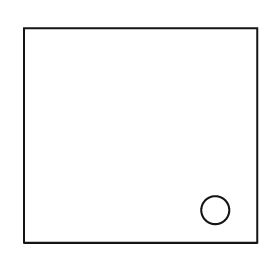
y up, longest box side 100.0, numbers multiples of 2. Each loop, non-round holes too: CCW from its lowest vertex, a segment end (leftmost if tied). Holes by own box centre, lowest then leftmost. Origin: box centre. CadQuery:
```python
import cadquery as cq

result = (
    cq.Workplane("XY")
    .moveTo(-50.0, -46.0)
    .lineTo(50.0, -46.0)
    .lineTo(50.0, 46.0)
    .lineTo(-50.0, 46.0)
    .close()
    .moveTo(32.0, -32.0)
    .circle(6.0)
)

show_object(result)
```